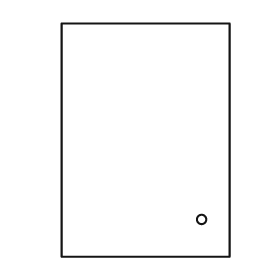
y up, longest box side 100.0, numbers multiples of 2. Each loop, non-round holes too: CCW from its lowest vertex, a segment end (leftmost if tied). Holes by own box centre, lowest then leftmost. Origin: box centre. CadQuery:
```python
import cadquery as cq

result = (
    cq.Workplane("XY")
    .moveTo(-36.0, -50.0)
    .lineTo(36.0, -50.0)
    .lineTo(36.0, 50.0)
    .lineTo(-36.0, 50.0)
    .close()
    .moveTo(24.0, -34.0)
    .circle(2.0)
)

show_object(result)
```